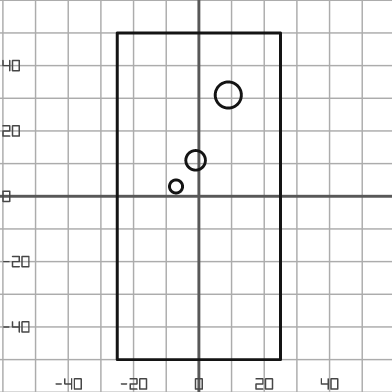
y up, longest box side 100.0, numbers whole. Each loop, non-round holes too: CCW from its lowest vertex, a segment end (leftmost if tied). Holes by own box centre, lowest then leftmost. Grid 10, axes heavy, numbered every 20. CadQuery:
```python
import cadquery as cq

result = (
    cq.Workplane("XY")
    .moveTo(-25.0, -50.0)
    .lineTo(25.0, -50.0)
    .lineTo(25.0, 50.0)
    .lineTo(-25.0, 50.0)
    .close()
    .moveTo(-7.0, 3.0)
    .circle(2.0)
    .moveTo(-1.0, 11.0)
    .circle(3.0)
    .moveTo(9.0, 31.0)
    .circle(4.0)
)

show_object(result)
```